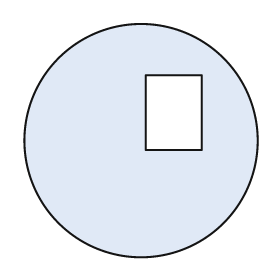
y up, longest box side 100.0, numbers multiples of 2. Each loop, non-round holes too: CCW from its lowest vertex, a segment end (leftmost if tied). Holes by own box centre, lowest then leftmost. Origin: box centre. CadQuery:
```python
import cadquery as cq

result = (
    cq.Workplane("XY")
    .moveTo(0.0, 0.0)
    .circle(50.0)
    .moveTo(2.0, -4.0)
    .lineTo(26.0, -4.0)
    .lineTo(26.0, 28.0)
    .lineTo(2.0, 28.0)
    .close()
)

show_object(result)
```